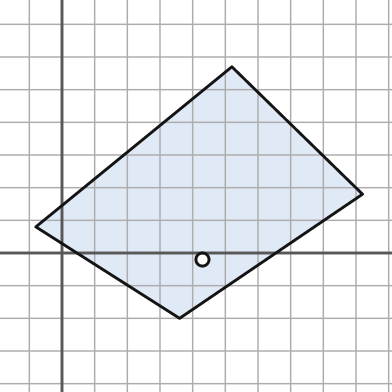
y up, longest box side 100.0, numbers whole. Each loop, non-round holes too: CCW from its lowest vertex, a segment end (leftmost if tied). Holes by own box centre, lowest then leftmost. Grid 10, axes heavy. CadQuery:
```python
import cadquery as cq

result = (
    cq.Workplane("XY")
    .moveTo(36.0, -20.0)
    .lineTo(92.0, 18.0)
    .lineTo(52.0, 57.0)
    .lineTo(-8.0, 8.0)
    .close()
    .moveTo(43.0, -2.0)
    .circle(2.0)
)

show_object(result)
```